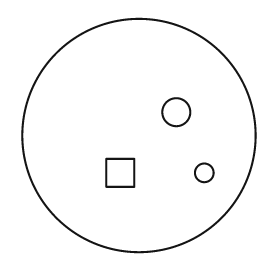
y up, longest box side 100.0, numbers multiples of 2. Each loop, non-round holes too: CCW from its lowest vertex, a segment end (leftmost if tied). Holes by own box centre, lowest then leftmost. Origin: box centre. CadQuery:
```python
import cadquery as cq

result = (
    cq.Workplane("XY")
    .moveTo(0.0, 0.0)
    .circle(50.0)
    .moveTo(-14.0, -22.0)
    .lineTo(-2.0, -22.0)
    .lineTo(-2.0, -10.0)
    .lineTo(-14.0, -10.0)
    .close()
    .moveTo(28.0, -16.0)
    .circle(4.0)
    .moveTo(16.0, 10.0)
    .circle(6.0)
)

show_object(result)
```